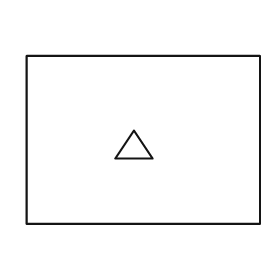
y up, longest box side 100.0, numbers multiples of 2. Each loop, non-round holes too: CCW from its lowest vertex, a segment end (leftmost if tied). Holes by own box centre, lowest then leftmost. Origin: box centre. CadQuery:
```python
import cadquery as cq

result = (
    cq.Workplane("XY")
    .moveTo(-50.0, -36.0)
    .lineTo(50.0, -36.0)
    .lineTo(50.0, 36.0)
    .lineTo(-50.0, 36.0)
    .close()
    .moveTo(-12.0, -8.0)
    .lineTo(4.0, -8.0)
    .lineTo(-4.0, 4.0)
    .close()
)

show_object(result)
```